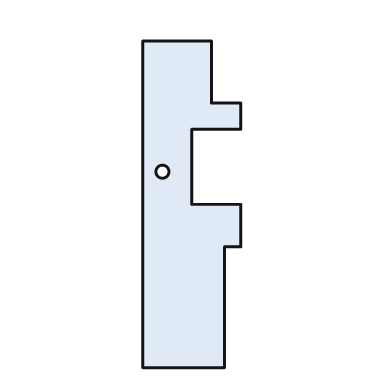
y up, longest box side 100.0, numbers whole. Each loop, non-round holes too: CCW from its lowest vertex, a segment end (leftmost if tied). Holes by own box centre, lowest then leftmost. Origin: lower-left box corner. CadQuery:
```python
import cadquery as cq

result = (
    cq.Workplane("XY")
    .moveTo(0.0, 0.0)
    .lineTo(25.0, 0.0)
    .lineTo(25.0, 37.0)
    .lineTo(30.0, 37.0)
    .lineTo(30.0, 50.0)
    .lineTo(15.0, 50.0)
    .lineTo(15.0, 73.0)
    .lineTo(30.0, 73.0)
    .lineTo(30.0, 81.0)
    .lineTo(21.0, 81.0)
    .lineTo(21.0, 100.0)
    .lineTo(0.0, 100.0)
    .close()
    .moveTo(6.0, 60.0)
    .circle(2.0)
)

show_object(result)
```